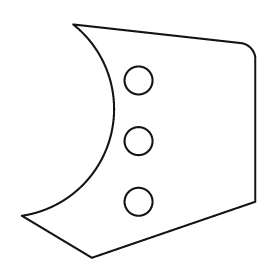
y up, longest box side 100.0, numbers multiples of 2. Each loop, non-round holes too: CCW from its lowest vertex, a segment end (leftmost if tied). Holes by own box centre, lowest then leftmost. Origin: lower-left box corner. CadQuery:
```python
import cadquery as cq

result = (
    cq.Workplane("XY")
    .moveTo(30.0, 0.0)
    .lineTo(100.0, 24.0)
    .lineTo(100.0, 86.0)
    .threePointArc((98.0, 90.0), (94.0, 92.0))
    .lineTo(22.0, 100.0)
    .threePointArc((38.0, 52.0), (0.0, 18.0))
    .close()
    .moveTo(50.0, 24.0)
    .circle(6.0)
    .moveTo(50.0, 50.0)
    .circle(6.0)
    .moveTo(50.0, 76.0)
    .circle(6.0)
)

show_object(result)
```